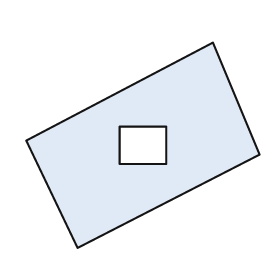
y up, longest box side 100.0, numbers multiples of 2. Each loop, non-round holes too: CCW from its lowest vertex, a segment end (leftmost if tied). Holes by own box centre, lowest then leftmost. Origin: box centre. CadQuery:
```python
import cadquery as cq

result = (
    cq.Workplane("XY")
    .moveTo(-28.0, -44.0)
    .lineTo(50.0, -4.0)
    .lineTo(30.0, 44.0)
    .lineTo(-50.0, 2.0)
    .close()
    .moveTo(-10.0, -8.0)
    .lineTo(10.0, -8.0)
    .lineTo(10.0, 8.0)
    .lineTo(-10.0, 8.0)
    .close()
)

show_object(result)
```